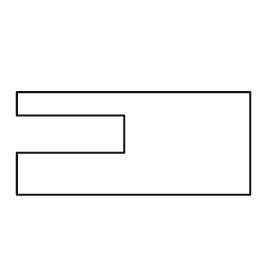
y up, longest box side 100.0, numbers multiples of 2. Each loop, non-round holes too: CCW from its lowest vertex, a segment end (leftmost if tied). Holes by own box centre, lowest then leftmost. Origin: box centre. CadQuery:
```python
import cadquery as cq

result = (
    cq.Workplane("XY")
    .moveTo(-50.0, -22.0)
    .lineTo(50.0, -22.0)
    .lineTo(50.0, 22.0)
    .lineTo(-50.0, 22.0)
    .lineTo(-50.0, 12.0)
    .lineTo(-4.0, 12.0)
    .lineTo(-4.0, -4.0)
    .lineTo(-50.0, -4.0)
    .close()
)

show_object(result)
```